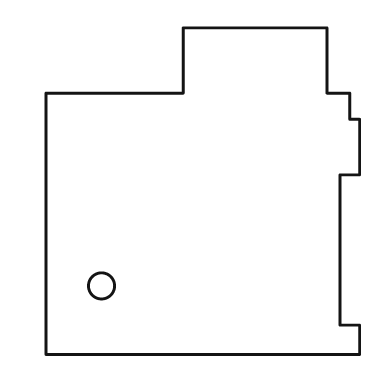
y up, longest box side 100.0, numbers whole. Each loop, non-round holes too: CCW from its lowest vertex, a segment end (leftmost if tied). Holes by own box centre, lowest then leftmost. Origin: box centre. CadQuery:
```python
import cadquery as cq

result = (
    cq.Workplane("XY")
    .moveTo(-48.0, -50.0)
    .lineTo(48.0, -50.0)
    .lineTo(48.0, -41.0)
    .lineTo(42.0, -41.0)
    .lineTo(42.0, 5.0)
    .lineTo(48.0, 5.0)
    .lineTo(48.0, 22.0)
    .lineTo(45.0, 22.0)
    .lineTo(45.0, 30.0)
    .lineTo(38.0, 30.0)
    .lineTo(38.0, 50.0)
    .lineTo(-6.0, 50.0)
    .lineTo(-6.0, 30.0)
    .lineTo(-48.0, 30.0)
    .close()
    .moveTo(-31.0, -29.0)
    .circle(4.0)
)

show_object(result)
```